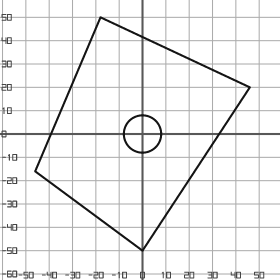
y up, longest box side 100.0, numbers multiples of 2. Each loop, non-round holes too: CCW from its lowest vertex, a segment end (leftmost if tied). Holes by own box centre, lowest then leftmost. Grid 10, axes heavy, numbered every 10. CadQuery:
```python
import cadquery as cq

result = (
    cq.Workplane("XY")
    .moveTo(0.0, -50.0)
    .lineTo(46.0, 20.0)
    .lineTo(-18.0, 50.0)
    .lineTo(-46.0, -16.0)
    .close()
    .moveTo(0.0, 0.0)
    .circle(8.0)
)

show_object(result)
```